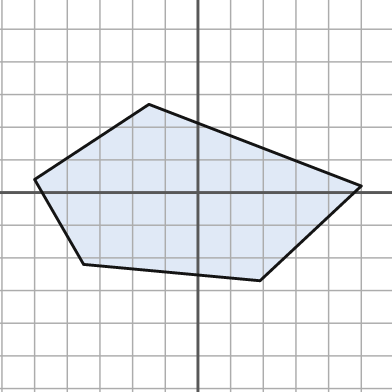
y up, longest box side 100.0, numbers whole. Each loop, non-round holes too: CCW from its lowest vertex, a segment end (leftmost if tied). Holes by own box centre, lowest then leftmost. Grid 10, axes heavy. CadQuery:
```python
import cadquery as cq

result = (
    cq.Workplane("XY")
    .moveTo(19.0, -27.0)
    .lineTo(50.0, 2.0)
    .lineTo(-15.0, 27.0)
    .lineTo(-50.0, 4.0)
    .lineTo(-35.0, -22.0)
    .close()
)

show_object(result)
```